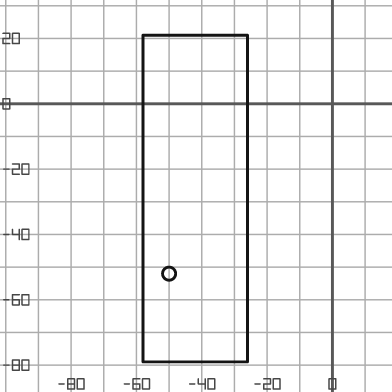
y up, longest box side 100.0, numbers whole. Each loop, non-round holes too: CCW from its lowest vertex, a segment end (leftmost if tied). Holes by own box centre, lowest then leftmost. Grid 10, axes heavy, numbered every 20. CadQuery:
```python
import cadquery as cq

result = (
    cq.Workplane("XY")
    .moveTo(-58.0, -79.0)
    .lineTo(-26.0, -79.0)
    .lineTo(-26.0, 21.0)
    .lineTo(-58.0, 21.0)
    .close()
    .moveTo(-50.0, -52.0)
    .circle(2.0)
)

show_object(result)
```